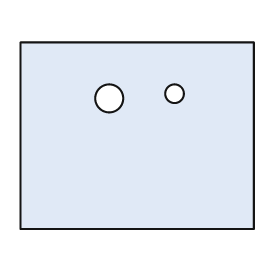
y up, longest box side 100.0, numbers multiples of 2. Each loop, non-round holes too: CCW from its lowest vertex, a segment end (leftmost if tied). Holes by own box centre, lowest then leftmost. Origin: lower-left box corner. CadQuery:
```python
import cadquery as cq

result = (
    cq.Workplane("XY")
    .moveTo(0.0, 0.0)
    .lineTo(100.0, 0.0)
    .lineTo(100.0, 80.0)
    .lineTo(0.0, 80.0)
    .close()
    .moveTo(38.0, 56.0)
    .circle(6.0)
    .moveTo(66.0, 58.0)
    .circle(4.0)
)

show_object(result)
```